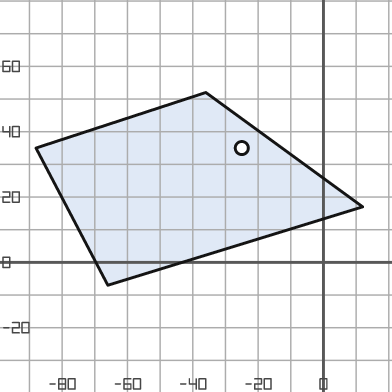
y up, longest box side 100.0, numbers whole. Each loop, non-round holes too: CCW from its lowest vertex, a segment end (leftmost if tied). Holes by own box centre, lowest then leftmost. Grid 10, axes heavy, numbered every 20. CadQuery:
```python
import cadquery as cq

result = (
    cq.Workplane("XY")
    .moveTo(-66.0, -7.0)
    .lineTo(12.0, 17.0)
    .lineTo(-36.0, 52.0)
    .lineTo(-88.0, 35.0)
    .close()
    .moveTo(-25.0, 35.0)
    .circle(2.0)
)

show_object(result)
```